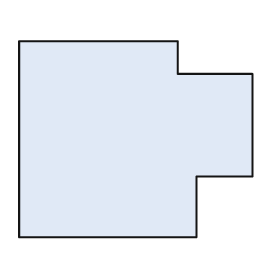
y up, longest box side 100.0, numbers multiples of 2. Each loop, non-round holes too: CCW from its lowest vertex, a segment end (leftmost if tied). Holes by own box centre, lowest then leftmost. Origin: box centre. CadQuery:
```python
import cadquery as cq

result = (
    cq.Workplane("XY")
    .moveTo(-50.0, -42.0)
    .lineTo(26.0, -42.0)
    .lineTo(26.0, -16.0)
    .lineTo(50.0, -16.0)
    .lineTo(50.0, 28.0)
    .lineTo(18.0, 28.0)
    .lineTo(18.0, 42.0)
    .lineTo(-50.0, 42.0)
    .close()
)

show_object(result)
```